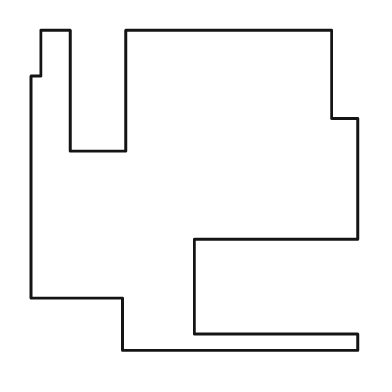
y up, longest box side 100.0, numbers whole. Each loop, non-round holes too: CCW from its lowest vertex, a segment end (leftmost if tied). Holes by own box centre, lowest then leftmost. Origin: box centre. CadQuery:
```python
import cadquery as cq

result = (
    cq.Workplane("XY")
    .moveTo(-22.0, -49.0)
    .lineTo(50.0, -49.0)
    .lineTo(50.0, -44.0)
    .lineTo(0.0, -44.0)
    .lineTo(0.0, -15.0)
    .lineTo(50.0, -15.0)
    .lineTo(50.0, 22.0)
    .lineTo(42.0, 22.0)
    .lineTo(42.0, 49.0)
    .lineTo(-21.0, 49.0)
    .lineTo(-21.0, 12.0)
    .lineTo(-38.0, 12.0)
    .lineTo(-38.0, 49.0)
    .lineTo(-47.0, 49.0)
    .lineTo(-47.0, 35.0)
    .lineTo(-50.0, 35.0)
    .lineTo(-50.0, -33.0)
    .lineTo(-22.0, -33.0)
    .close()
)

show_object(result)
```